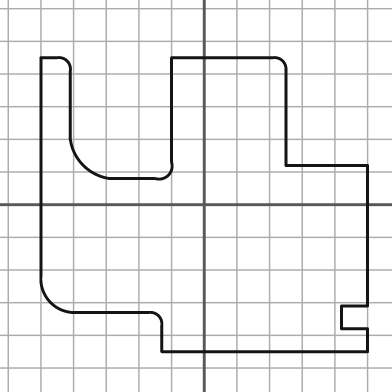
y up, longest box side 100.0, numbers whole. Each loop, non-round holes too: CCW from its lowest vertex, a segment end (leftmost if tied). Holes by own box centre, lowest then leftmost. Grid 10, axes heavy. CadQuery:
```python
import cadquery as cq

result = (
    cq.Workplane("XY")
    .moveTo(-13.0, -45.0)
    .lineTo(50.0, -45.0)
    .lineTo(50.0, -38.0)
    .lineTo(42.0, -38.0)
    .lineTo(42.0, -31.0)
    .lineTo(50.0, -31.0)
    .lineTo(50.0, 12.0)
    .lineTo(25.0, 12.0)
    .lineTo(25.0, 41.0)
    .threePointArc((24.0, 44.0), (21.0, 45.0))
    .lineTo(-10.0, 45.0)
    .lineTo(-10.0, 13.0)
    .threePointArc((-11.0, 9.0), (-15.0, 8.0))
    .lineTo(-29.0, 8.0)
    .threePointArc((-37.0, 12.0), (-41.0, 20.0))
    .lineTo(-41.0, 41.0)
    .threePointArc((-42.0, 44.0), (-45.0, 45.0))
    .lineTo(-50.0, 45.0)
    .lineTo(-50.0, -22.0)
    .threePointArc((-47.0, -30.0), (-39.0, -33.0))
    .lineTo(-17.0, -33.0)
    .threePointArc((-14.0, -34.0), (-13.0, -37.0))
    .close()
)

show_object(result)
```